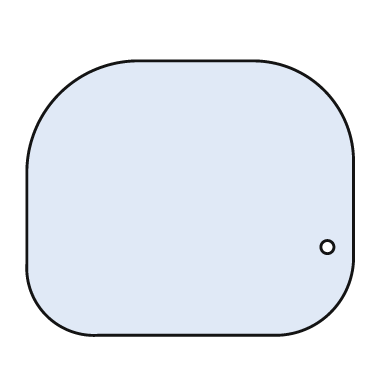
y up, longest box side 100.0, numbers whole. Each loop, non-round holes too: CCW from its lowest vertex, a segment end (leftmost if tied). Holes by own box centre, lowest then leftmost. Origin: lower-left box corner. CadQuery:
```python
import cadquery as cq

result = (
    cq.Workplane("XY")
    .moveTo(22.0, 0.0)
    .lineTo(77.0, 0.0)
    .threePointArc((93.0, 7.0), (100.0, 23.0))
    .lineTo(100.0, 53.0)
    .threePointArc((91.0, 75.0), (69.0, 84.0))
    .lineTo(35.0, 84.0)
    .threePointArc((10.0, 74.0), (0.0, 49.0))
    .lineTo(0.0, 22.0)
    .threePointArc((6.0, 6.0), (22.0, 0.0))
    .close()
    .moveTo(92.0, 27.0)
    .circle(2.0)
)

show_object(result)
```